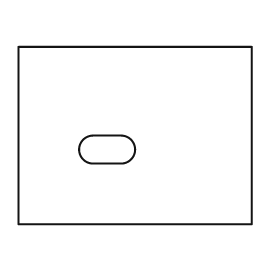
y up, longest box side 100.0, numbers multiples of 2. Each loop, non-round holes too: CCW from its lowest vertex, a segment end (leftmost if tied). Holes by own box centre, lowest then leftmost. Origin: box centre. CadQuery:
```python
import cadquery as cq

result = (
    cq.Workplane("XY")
    .moveTo(-50.0, -38.0)
    .lineTo(50.0, -38.0)
    .lineTo(50.0, 38.0)
    .lineTo(-50.0, 38.0)
    .close()
    .moveTo(-18.0, -12.0)
    .lineTo(-6.0, -12.0)
    .threePointArc((0.0, -6.0), (-6.0, 0.0))
    .lineTo(-18.0, 0.0)
    .threePointArc((-24.0, -6.0), (-18.0, -12.0))
    .close()
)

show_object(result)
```